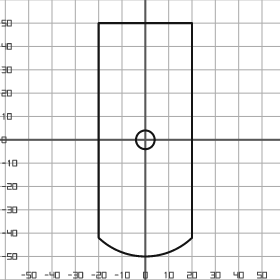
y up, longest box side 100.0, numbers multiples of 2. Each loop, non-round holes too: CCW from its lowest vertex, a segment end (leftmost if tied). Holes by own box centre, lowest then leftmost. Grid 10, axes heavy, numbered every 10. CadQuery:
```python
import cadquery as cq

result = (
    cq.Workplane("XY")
    .moveTo(-20.0, -42.0)
    .threePointArc((0.0, -50.0), (20.0, -42.0))
    .lineTo(20.0, 50.0)
    .lineTo(-20.0, 50.0)
    .close()
    .moveTo(0.0, 0.0)
    .circle(4.0)
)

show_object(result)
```